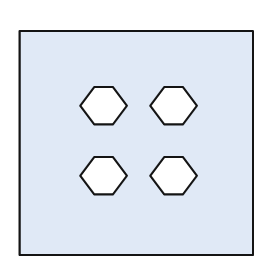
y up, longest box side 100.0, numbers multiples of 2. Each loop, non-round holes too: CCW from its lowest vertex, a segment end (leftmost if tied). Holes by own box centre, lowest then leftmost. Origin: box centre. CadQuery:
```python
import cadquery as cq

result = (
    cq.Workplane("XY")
    .moveTo(-50.0, -48.0)
    .lineTo(50.0, -48.0)
    .lineTo(50.0, 48.0)
    .lineTo(-50.0, 48.0)
    .close()
    .moveTo(-18.0, -22.0)
    .lineTo(-10.0, -22.0)
    .lineTo(-4.0, -14.0)
    .lineTo(-10.0, -6.0)
    .lineTo(-18.0, -6.0)
    .lineTo(-24.0, -14.0)
    .close()
    .moveTo(12.0, -22.0)
    .lineTo(20.0, -22.0)
    .lineTo(26.0, -14.0)
    .lineTo(20.0, -6.0)
    .lineTo(12.0, -6.0)
    .lineTo(6.0, -14.0)
    .close()
    .moveTo(-18.0, 8.0)
    .lineTo(-10.0, 8.0)
    .lineTo(-4.0, 16.0)
    .lineTo(-10.0, 24.0)
    .lineTo(-18.0, 24.0)
    .lineTo(-24.0, 16.0)
    .close()
    .moveTo(12.0, 8.0)
    .lineTo(20.0, 8.0)
    .lineTo(26.0, 16.0)
    .lineTo(20.0, 24.0)
    .lineTo(12.0, 24.0)
    .lineTo(6.0, 16.0)
    .close()
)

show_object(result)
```